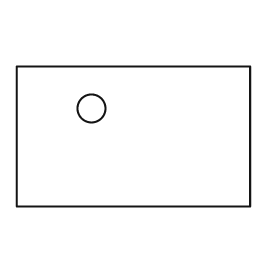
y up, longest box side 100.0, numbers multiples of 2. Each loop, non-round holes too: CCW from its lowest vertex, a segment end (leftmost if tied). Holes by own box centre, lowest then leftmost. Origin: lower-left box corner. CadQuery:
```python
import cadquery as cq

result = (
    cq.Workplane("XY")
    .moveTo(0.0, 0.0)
    .lineTo(100.0, 0.0)
    .lineTo(100.0, 60.0)
    .lineTo(0.0, 60.0)
    .close()
    .moveTo(32.0, 42.0)
    .circle(6.0)
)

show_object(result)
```